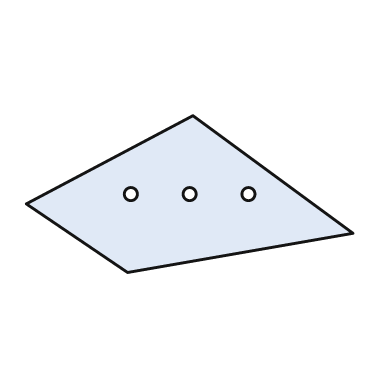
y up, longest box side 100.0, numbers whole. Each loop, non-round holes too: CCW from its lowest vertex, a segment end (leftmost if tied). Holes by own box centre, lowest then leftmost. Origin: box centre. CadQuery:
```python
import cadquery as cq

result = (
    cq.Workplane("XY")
    .moveTo(-19.0, -24.0)
    .lineTo(50.0, -12.0)
    .lineTo(1.0, 24.0)
    .lineTo(-50.0, -3.0)
    .close()
    .moveTo(-18.0, 0.0)
    .circle(2.0)
    .moveTo(0.0, 0.0)
    .circle(2.0)
    .moveTo(18.0, 0.0)
    .circle(2.0)
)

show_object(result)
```